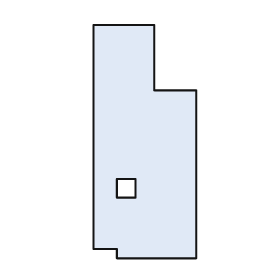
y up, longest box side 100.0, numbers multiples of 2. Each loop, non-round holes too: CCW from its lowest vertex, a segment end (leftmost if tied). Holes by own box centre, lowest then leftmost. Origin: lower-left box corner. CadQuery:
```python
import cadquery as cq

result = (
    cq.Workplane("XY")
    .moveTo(10.0, 0.0)
    .lineTo(44.0, 0.0)
    .lineTo(44.0, 72.0)
    .lineTo(26.0, 72.0)
    .lineTo(26.0, 100.0)
    .lineTo(0.0, 100.0)
    .lineTo(0.0, 4.0)
    .lineTo(10.0, 4.0)
    .close()
    .moveTo(10.0, 26.0)
    .lineTo(18.0, 26.0)
    .lineTo(18.0, 34.0)
    .lineTo(10.0, 34.0)
    .close()
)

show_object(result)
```